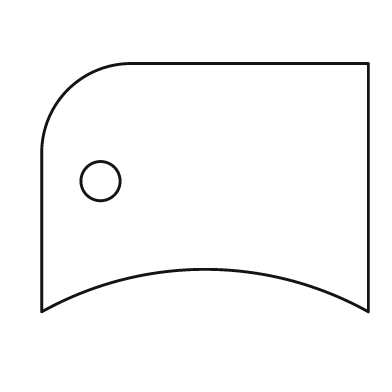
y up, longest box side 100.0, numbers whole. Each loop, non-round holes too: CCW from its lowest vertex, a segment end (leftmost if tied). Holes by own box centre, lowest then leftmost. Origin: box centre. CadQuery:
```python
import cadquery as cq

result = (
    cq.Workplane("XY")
    .moveTo(-50.0, -38.0)
    .threePointArc((0.0, -25.0), (50.0, -38.0))
    .lineTo(50.0, 38.0)
    .lineTo(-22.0, 38.0)
    .threePointArc((-42.0, 30.0), (-50.0, 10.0))
    .close()
    .moveTo(-32.0, 2.0)
    .circle(6.0)
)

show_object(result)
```